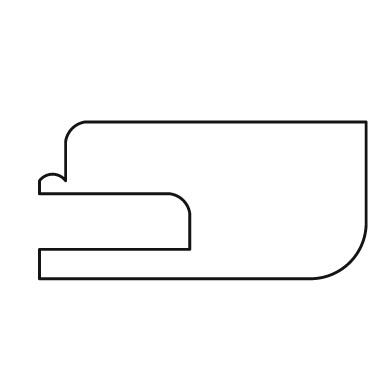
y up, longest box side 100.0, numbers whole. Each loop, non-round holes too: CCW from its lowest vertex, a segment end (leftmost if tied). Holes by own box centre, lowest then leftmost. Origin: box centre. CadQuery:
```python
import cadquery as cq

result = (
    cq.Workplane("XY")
    .moveTo(-50.0, -24.0)
    .lineTo(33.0, -24.0)
    .threePointArc((45.0, -19.0), (50.0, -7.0))
    .lineTo(50.0, 24.0)
    .lineTo(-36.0, 24.0)
    .threePointArc((-40.0, 22.0), (-42.0, 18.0))
    .lineTo(-42.0, 6.0)
    .threePointArc((-46.0, 8.0), (-50.0, 6.0))
    .lineTo(-50.0, 2.0)
    .lineTo(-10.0, 2.0)
    .threePointArc((-6.0, 0.0), (-4.0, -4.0))
    .lineTo(-4.0, -15.0)
    .lineTo(-50.0, -15.0)
    .close()
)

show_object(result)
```